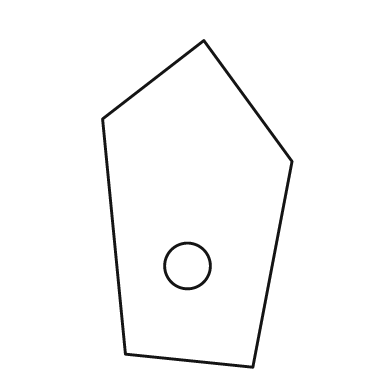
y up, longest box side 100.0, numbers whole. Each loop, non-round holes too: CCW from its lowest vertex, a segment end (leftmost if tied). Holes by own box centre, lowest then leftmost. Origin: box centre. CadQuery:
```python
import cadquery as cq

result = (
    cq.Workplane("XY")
    .moveTo(17.0, -50.0)
    .lineTo(29.0, 13.0)
    .lineTo(2.0, 50.0)
    .lineTo(-29.0, 26.0)
    .lineTo(-22.0, -46.0)
    .close()
    .moveTo(-3.0, -19.0)
    .circle(7.0)
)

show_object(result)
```